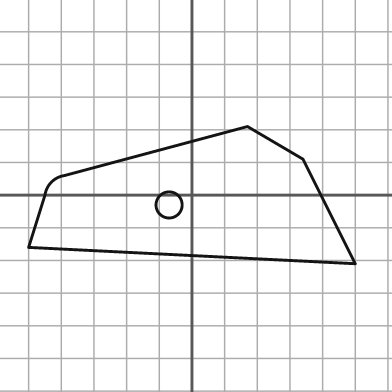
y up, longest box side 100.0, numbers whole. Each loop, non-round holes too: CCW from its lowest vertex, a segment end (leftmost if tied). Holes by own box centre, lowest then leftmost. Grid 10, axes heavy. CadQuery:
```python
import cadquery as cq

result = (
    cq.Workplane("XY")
    .moveTo(50.0, -21.0)
    .lineTo(34.0, 11.0)
    .lineTo(17.0, 21.0)
    .lineTo(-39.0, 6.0)
    .threePointArc((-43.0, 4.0), (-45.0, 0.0))
    .lineTo(-50.0, -16.0)
    .close()
    .moveTo(-7.0, -3.0)
    .circle(4.0)
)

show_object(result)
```